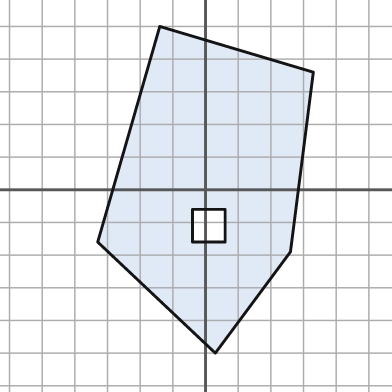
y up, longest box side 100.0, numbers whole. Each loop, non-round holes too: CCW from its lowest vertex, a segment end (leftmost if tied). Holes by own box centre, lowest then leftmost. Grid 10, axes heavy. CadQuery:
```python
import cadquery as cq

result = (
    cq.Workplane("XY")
    .moveTo(3.0, -50.0)
    .lineTo(26.0, -19.0)
    .lineTo(33.0, 36.0)
    .lineTo(-14.0, 50.0)
    .lineTo(-33.0, -16.0)
    .close()
    .moveTo(-4.0, -16.0)
    .lineTo(6.0, -16.0)
    .lineTo(6.0, -6.0)
    .lineTo(-4.0, -6.0)
    .close()
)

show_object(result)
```